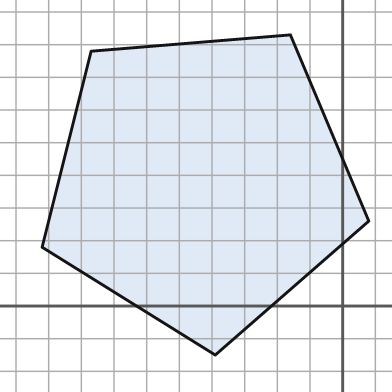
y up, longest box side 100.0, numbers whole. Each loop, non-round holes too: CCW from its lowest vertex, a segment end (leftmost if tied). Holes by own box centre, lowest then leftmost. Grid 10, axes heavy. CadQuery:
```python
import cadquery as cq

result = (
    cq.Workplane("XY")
    .moveTo(-39.0, -15.0)
    .lineTo(8.0, 26.0)
    .lineTo(-16.0, 83.0)
    .lineTo(-77.0, 78.0)
    .lineTo(-92.0, 18.0)
    .close()
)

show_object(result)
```